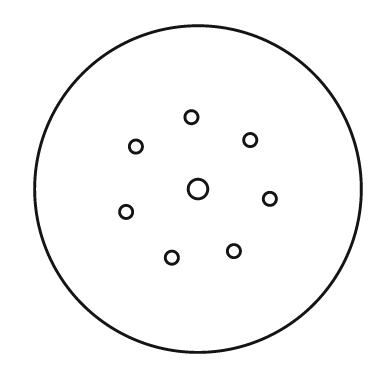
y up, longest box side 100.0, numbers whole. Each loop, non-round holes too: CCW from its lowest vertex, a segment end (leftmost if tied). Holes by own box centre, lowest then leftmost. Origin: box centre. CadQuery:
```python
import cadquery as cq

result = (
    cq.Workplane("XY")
    .moveTo(0.0, 0.0)
    .circle(50.0)
    .moveTo(-8.0, -21.0)
    .circle(2.0)
    .moveTo(11.0, -19.0)
    .circle(2.0)
    .moveTo(-22.0, -7.0)
    .circle(2.0)
    .moveTo(22.0, -3.0)
    .circle(2.0)
    .moveTo(0.0, 0.0)
    .circle(3.0)
    .moveTo(-19.0, 13.0)
    .circle(2.0)
    .moveTo(16.0, 15.0)
    .circle(2.0)
    .moveTo(-2.0, 22.0)
    .circle(2.0)
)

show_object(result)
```